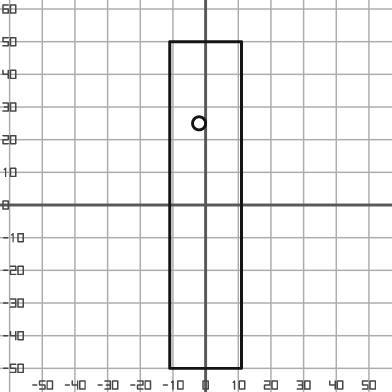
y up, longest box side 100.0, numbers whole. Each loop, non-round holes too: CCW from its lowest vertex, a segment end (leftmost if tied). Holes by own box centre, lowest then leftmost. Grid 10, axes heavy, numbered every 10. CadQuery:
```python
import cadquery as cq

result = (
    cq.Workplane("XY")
    .moveTo(-11.0, -50.0)
    .lineTo(11.0, -50.0)
    .lineTo(11.0, 50.0)
    .lineTo(-11.0, 50.0)
    .close()
    .moveTo(-2.0, 25.0)
    .circle(2.0)
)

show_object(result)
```